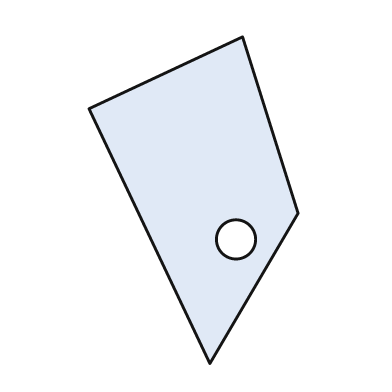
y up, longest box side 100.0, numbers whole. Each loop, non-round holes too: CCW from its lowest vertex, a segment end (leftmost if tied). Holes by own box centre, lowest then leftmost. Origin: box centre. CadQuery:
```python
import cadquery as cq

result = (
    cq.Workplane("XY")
    .moveTo(5.0, -50.0)
    .lineTo(32.0, -4.0)
    .lineTo(15.0, 50.0)
    .lineTo(-32.0, 28.0)
    .close()
    .moveTo(13.0, -12.0)
    .circle(6.0)
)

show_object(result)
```